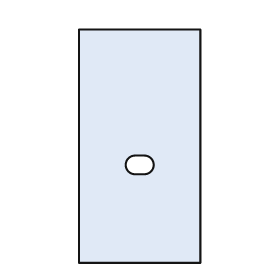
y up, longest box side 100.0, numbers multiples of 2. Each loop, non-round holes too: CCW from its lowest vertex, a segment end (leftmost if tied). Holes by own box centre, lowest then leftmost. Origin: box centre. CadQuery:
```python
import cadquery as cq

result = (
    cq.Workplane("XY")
    .moveTo(-26.0, -50.0)
    .lineTo(26.0, -50.0)
    .lineTo(26.0, 50.0)
    .lineTo(-26.0, 50.0)
    .close()
    .moveTo(-2.0, -12.0)
    .lineTo(2.0, -12.0)
    .threePointArc((6.0, -8.0), (2.0, -4.0))
    .lineTo(-2.0, -4.0)
    .threePointArc((-6.0, -8.0), (-2.0, -12.0))
    .close()
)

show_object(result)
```